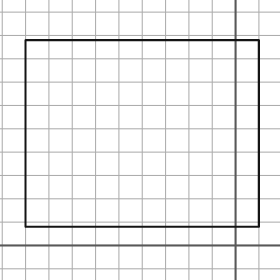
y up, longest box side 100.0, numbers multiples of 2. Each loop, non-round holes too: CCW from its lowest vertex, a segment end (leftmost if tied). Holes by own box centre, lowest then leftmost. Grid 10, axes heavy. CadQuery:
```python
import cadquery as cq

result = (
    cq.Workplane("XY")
    .moveTo(-90.0, 8.0)
    .lineTo(10.0, 8.0)
    .lineTo(10.0, 88.0)
    .lineTo(-90.0, 88.0)
    .close()
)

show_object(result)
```